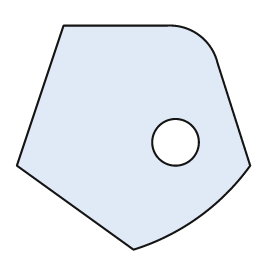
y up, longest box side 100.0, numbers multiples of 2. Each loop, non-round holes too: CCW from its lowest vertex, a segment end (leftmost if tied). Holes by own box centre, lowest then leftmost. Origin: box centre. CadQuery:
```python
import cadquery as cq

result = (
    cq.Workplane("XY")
    .moveTo(0.0, -48.0)
    .threePointArc((28.0, -34.0), (50.0, -12.0))
    .lineTo(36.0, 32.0)
    .threePointArc((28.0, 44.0), (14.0, 48.0))
    .lineTo(-30.0, 48.0)
    .lineTo(-50.0, -12.0)
    .close()
    .moveTo(18.0, -2.0)
    .circle(10.0)
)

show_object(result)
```